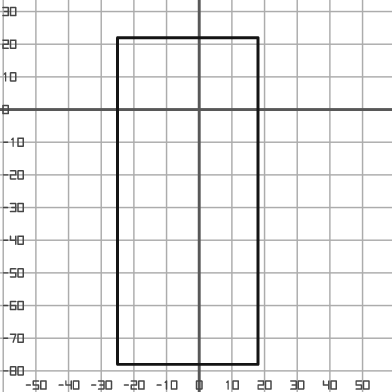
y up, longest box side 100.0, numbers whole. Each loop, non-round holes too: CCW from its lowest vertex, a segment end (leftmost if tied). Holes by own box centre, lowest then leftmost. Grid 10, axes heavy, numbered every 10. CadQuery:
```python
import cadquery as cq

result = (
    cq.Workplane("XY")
    .moveTo(-25.0, -78.0)
    .lineTo(18.0, -78.0)
    .lineTo(18.0, 22.0)
    .lineTo(-25.0, 22.0)
    .close()
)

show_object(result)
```